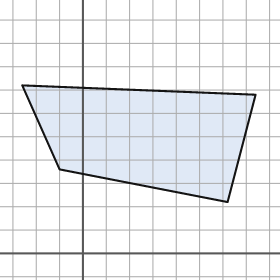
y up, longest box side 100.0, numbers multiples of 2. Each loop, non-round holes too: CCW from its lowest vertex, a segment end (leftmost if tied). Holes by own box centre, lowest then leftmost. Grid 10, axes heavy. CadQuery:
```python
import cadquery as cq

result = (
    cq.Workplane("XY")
    .moveTo(62.0, 22.0)
    .lineTo(74.0, 68.0)
    .lineTo(-26.0, 72.0)
    .lineTo(-10.0, 36.0)
    .close()
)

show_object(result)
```